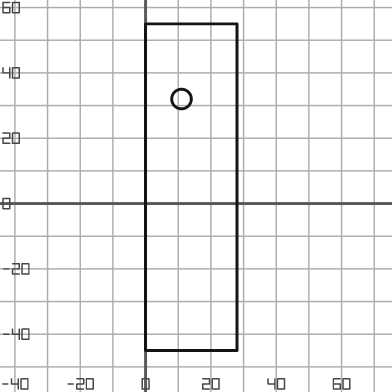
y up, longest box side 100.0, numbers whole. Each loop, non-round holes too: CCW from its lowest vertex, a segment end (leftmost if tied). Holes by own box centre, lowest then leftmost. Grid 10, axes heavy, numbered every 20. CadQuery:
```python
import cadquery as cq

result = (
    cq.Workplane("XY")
    .moveTo(0.0, -45.0)
    .lineTo(28.0, -45.0)
    .lineTo(28.0, 55.0)
    .lineTo(0.0, 55.0)
    .close()
    .moveTo(11.0, 32.0)
    .circle(3.0)
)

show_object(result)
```